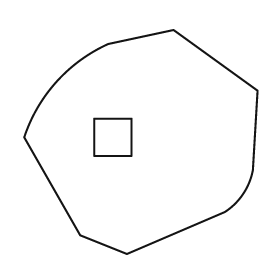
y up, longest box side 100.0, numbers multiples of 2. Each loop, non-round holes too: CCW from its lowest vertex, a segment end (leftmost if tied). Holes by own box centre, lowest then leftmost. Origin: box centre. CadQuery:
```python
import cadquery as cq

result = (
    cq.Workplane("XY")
    .moveTo(-6.0, -48.0)
    .lineTo(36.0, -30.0)
    .threePointArc((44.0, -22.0), (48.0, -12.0))
    .lineTo(50.0, 22.0)
    .lineTo(14.0, 48.0)
    .lineTo(-14.0, 42.0)
    .threePointArc((-36.0, 26.0), (-50.0, 2.0))
    .lineTo(-26.0, -40.0)
    .close()
    .moveTo(-20.0, -6.0)
    .lineTo(-4.0, -6.0)
    .lineTo(-4.0, 10.0)
    .lineTo(-20.0, 10.0)
    .close()
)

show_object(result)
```